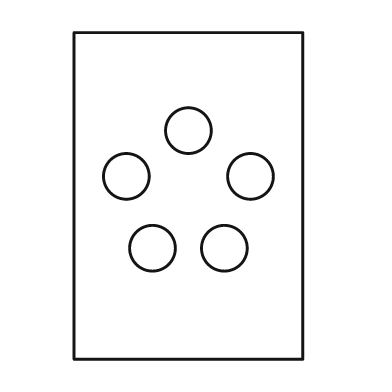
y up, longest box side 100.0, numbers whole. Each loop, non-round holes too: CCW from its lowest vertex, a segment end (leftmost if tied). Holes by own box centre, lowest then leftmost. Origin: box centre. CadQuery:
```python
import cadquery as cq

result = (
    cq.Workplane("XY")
    .moveTo(-35.0, -50.0)
    .lineTo(35.0, -50.0)
    .lineTo(35.0, 50.0)
    .lineTo(-35.0, 50.0)
    .close()
    .moveTo(-11.0, -16.0)
    .circle(7.0)
    .moveTo(11.0, -16.0)
    .circle(7.0)
    .moveTo(-19.0, 6.0)
    .circle(7.0)
    .moveTo(19.0, 6.0)
    .circle(7.0)
    .moveTo(0.0, 20.0)
    .circle(7.0)
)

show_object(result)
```